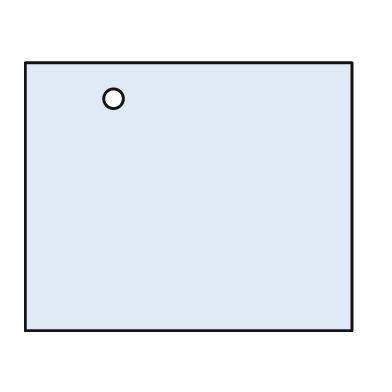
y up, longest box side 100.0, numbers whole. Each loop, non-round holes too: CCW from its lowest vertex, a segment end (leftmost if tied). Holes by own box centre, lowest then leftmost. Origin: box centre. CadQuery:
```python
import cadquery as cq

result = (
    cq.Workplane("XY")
    .moveTo(-50.0, -41.0)
    .lineTo(50.0, -41.0)
    .lineTo(50.0, 41.0)
    .lineTo(-50.0, 41.0)
    .close()
    .moveTo(-23.0, 30.0)
    .circle(3.0)
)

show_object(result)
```